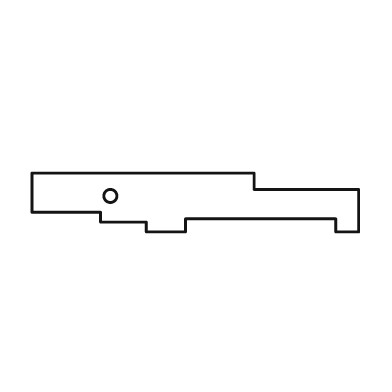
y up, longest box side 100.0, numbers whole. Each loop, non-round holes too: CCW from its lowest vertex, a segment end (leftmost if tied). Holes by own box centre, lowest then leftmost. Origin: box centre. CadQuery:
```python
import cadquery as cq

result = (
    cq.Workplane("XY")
    .moveTo(-15.0, -9.0)
    .lineTo(-3.0, -9.0)
    .lineTo(-3.0, -5.0)
    .lineTo(43.0, -5.0)
    .lineTo(43.0, -9.0)
    .lineTo(50.0, -9.0)
    .lineTo(50.0, 4.0)
    .lineTo(18.0, 4.0)
    .lineTo(18.0, 9.0)
    .lineTo(-50.0, 9.0)
    .lineTo(-50.0, -3.0)
    .lineTo(-29.0, -3.0)
    .lineTo(-29.0, -6.0)
    .lineTo(-15.0, -6.0)
    .close()
    .moveTo(-26.0, 2.0)
    .circle(2.0)
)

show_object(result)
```